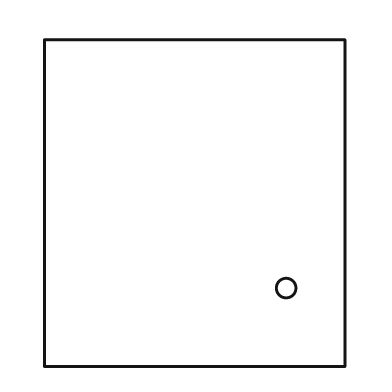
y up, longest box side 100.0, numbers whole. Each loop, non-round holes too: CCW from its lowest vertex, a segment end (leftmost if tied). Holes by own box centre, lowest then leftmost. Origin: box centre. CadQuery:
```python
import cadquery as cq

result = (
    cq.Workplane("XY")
    .moveTo(-46.0, -50.0)
    .lineTo(46.0, -50.0)
    .lineTo(46.0, 50.0)
    .lineTo(-46.0, 50.0)
    .close()
    .moveTo(28.0, -26.0)
    .circle(3.0)
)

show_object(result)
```